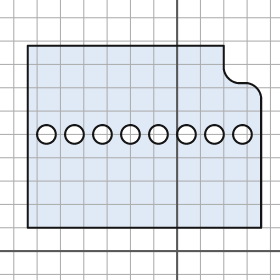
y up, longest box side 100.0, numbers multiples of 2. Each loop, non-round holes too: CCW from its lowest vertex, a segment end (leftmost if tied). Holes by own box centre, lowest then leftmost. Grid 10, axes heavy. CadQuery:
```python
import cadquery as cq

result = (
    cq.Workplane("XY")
    .moveTo(-64.0, 10.0)
    .lineTo(36.0, 10.0)
    .lineTo(36.0, 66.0)
    .threePointArc((34.0, 70.0), (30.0, 72.0))
    .lineTo(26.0, 72.0)
    .threePointArc((22.0, 74.0), (20.0, 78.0))
    .lineTo(20.0, 88.0)
    .lineTo(-64.0, 88.0)
    .close()
    .moveTo(-56.0, 50.0)
    .circle(4.0)
    .moveTo(-44.0, 50.0)
    .circle(4.0)
    .moveTo(-32.0, 50.0)
    .circle(4.0)
    .moveTo(-20.0, 50.0)
    .circle(4.0)
    .moveTo(-8.0, 50.0)
    .circle(4.0)
    .moveTo(4.0, 50.0)
    .circle(4.0)
    .moveTo(16.0, 50.0)
    .circle(4.0)
    .moveTo(28.0, 50.0)
    .circle(4.0)
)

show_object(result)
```